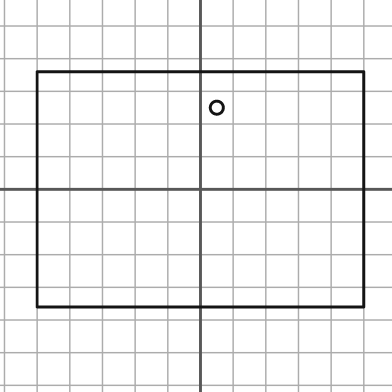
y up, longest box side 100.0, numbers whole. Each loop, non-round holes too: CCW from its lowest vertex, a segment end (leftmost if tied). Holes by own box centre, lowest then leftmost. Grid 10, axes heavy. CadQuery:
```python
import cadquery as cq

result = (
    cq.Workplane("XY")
    .moveTo(-50.0, -36.0)
    .lineTo(50.0, -36.0)
    .lineTo(50.0, 36.0)
    .lineTo(-50.0, 36.0)
    .close()
    .moveTo(5.0, 25.0)
    .circle(2.0)
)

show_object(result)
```